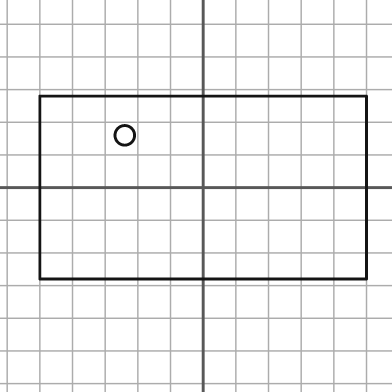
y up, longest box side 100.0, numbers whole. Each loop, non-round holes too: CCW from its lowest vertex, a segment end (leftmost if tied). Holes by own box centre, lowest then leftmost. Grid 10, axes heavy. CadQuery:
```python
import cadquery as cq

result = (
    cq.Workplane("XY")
    .moveTo(-50.0, -28.0)
    .lineTo(50.0, -28.0)
    .lineTo(50.0, 28.0)
    .lineTo(-50.0, 28.0)
    .close()
    .moveTo(-24.0, 16.0)
    .circle(3.0)
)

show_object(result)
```